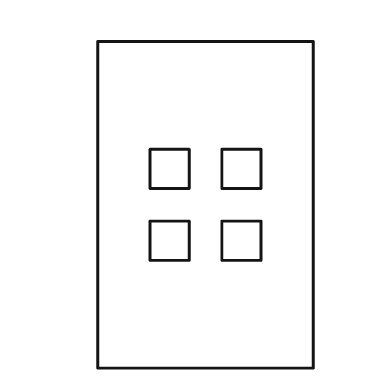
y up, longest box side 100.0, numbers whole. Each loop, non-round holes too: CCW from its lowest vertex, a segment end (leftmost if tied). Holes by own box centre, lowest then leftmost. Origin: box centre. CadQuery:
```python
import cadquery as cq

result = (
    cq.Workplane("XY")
    .moveTo(-33.0, -50.0)
    .lineTo(33.0, -50.0)
    .lineTo(33.0, 50.0)
    .lineTo(-33.0, 50.0)
    .close()
    .moveTo(-17.0, -17.0)
    .lineTo(-5.0, -17.0)
    .lineTo(-5.0, -5.0)
    .lineTo(-17.0, -5.0)
    .close()
    .moveTo(5.0, -17.0)
    .lineTo(17.0, -17.0)
    .lineTo(17.0, -5.0)
    .lineTo(5.0, -5.0)
    .close()
    .moveTo(-17.0, 5.0)
    .lineTo(-5.0, 5.0)
    .lineTo(-5.0, 17.0)
    .lineTo(-17.0, 17.0)
    .close()
    .moveTo(5.0, 5.0)
    .lineTo(17.0, 5.0)
    .lineTo(17.0, 17.0)
    .lineTo(5.0, 17.0)
    .close()
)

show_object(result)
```